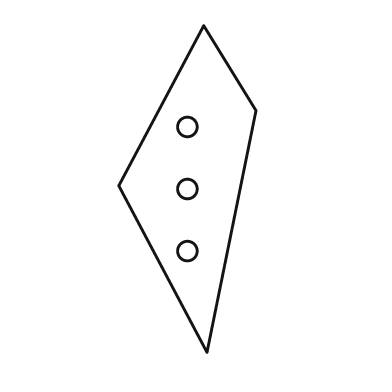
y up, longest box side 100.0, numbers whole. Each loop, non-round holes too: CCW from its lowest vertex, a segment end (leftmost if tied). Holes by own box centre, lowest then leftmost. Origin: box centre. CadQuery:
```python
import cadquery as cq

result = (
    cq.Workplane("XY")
    .moveTo(6.0, -50.0)
    .lineTo(21.0, 24.0)
    .lineTo(5.0, 50.0)
    .lineTo(-21.0, 1.0)
    .close()
    .moveTo(0.0, -19.0)
    .circle(3.0)
    .moveTo(0.0, 0.0)
    .circle(3.0)
    .moveTo(0.0, 19.0)
    .circle(3.0)
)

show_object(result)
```